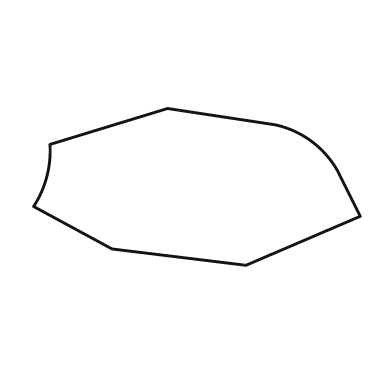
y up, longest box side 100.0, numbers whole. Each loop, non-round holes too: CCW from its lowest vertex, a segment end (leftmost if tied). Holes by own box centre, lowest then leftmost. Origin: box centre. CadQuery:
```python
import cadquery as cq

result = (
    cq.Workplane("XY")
    .moveTo(15.0, -24.0)
    .lineTo(50.0, -9.0)
    .lineTo(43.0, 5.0)
    .threePointArc((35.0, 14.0), (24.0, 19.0))
    .lineTo(-9.0, 24.0)
    .lineTo(-45.0, 13.0)
    .threePointArc((-46.0, 3.0), (-50.0, -6.0))
    .lineTo(-26.0, -19.0)
    .close()
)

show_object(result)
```